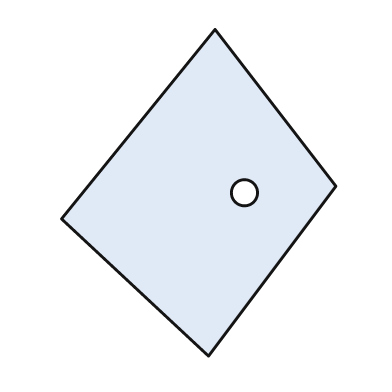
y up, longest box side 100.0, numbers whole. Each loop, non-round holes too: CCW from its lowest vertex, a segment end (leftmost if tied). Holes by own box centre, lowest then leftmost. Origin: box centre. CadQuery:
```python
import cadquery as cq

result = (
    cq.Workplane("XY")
    .moveTo(3.0, -50.0)
    .lineTo(42.0, 2.0)
    .lineTo(5.0, 50.0)
    .lineTo(-42.0, -8.0)
    .close()
    .moveTo(14.0, 0.0)
    .circle(4.0)
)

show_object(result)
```